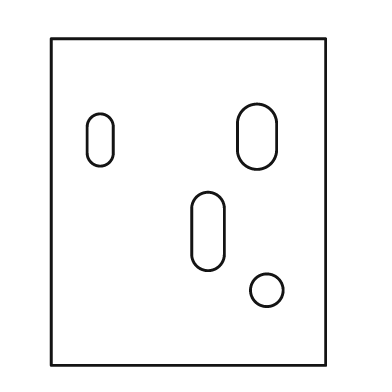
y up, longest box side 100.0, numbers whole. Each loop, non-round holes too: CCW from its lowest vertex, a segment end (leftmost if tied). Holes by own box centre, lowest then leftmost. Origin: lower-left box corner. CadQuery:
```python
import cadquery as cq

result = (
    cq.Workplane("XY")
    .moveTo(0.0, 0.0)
    .lineTo(84.0, 0.0)
    .lineTo(84.0, 100.0)
    .lineTo(0.0, 100.0)
    .close()
    .moveTo(66.0, 23.0)
    .circle(5.0)
    .moveTo(43.0, 34.0)
    .threePointArc((48.0, 29.0), (53.0, 34.0))
    .lineTo(53.0, 48.0)
    .threePointArc((48.0, 53.0), (43.0, 48.0))
    .close()
    .moveTo(11.0, 65.0)
    .threePointArc((15.0, 61.0), (19.0, 65.0))
    .lineTo(19.0, 73.0)
    .threePointArc((15.0, 77.0), (11.0, 73.0))
    .close()
    .moveTo(57.0, 66.0)
    .threePointArc((63.0, 60.0), (69.0, 66.0))
    .lineTo(69.0, 74.0)
    .threePointArc((63.0, 80.0), (57.0, 74.0))
    .close()
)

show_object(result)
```